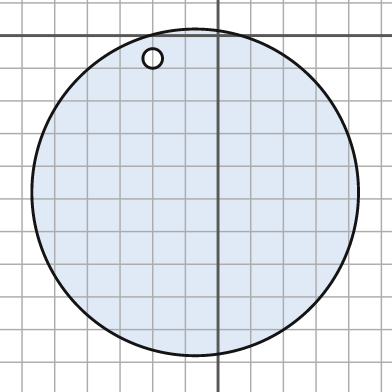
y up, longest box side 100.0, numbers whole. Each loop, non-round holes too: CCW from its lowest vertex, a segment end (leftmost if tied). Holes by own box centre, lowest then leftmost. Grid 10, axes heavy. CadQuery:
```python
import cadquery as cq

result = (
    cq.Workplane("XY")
    .moveTo(-7.0, -48.0)
    .circle(50.0)
    .moveTo(-20.0, -7.0)
    .circle(3.0)
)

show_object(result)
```